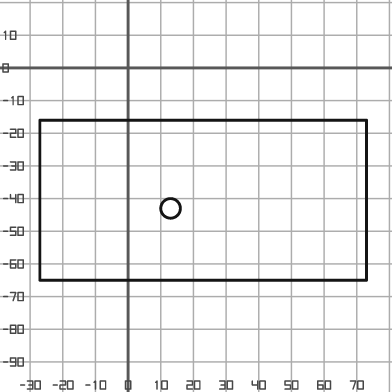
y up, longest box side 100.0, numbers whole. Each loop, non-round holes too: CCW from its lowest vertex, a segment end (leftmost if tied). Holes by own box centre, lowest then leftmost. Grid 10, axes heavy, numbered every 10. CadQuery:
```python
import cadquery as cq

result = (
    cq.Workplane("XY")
    .moveTo(-27.0, -65.0)
    .lineTo(73.0, -65.0)
    .lineTo(73.0, -16.0)
    .lineTo(-27.0, -16.0)
    .close()
    .moveTo(13.0, -43.0)
    .circle(3.0)
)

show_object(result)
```